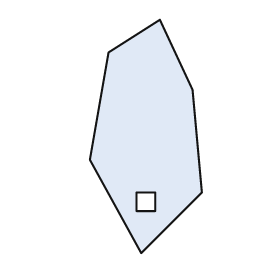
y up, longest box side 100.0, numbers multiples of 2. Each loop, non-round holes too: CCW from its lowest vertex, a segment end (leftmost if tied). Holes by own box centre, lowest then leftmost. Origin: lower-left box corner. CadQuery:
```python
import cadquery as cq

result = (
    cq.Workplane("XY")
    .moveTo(22.0, 0.0)
    .lineTo(48.0, 26.0)
    .lineTo(44.0, 70.0)
    .lineTo(30.0, 100.0)
    .lineTo(8.0, 86.0)
    .lineTo(0.0, 40.0)
    .close()
    .moveTo(20.0, 18.0)
    .lineTo(28.0, 18.0)
    .lineTo(28.0, 26.0)
    .lineTo(20.0, 26.0)
    .close()
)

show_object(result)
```